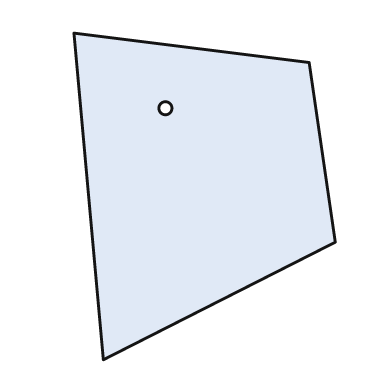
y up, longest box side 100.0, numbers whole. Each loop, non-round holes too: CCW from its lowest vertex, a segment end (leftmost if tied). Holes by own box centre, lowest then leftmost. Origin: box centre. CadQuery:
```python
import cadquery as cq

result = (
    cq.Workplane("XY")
    .moveTo(-31.0, -50.0)
    .lineTo(40.0, -14.0)
    .lineTo(32.0, 41.0)
    .lineTo(-40.0, 50.0)
    .close()
    .moveTo(-12.0, 27.0)
    .circle(2.0)
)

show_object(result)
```